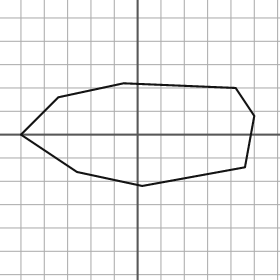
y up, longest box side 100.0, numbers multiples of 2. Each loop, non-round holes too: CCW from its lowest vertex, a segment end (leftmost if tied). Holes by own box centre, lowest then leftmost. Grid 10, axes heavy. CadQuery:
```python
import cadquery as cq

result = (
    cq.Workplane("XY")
    .moveTo(2.0, -22.0)
    .lineTo(46.0, -14.0)
    .lineTo(50.0, 8.0)
    .lineTo(42.0, 20.0)
    .lineTo(-6.0, 22.0)
    .lineTo(-34.0, 16.0)
    .lineTo(-50.0, 0.0)
    .lineTo(-26.0, -16.0)
    .close()
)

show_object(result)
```